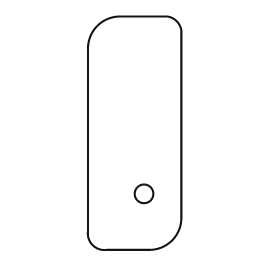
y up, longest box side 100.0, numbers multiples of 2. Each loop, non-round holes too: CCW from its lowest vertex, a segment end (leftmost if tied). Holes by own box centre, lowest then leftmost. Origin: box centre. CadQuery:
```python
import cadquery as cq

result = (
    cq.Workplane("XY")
    .moveTo(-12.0, -50.0)
    .lineTo(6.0, -50.0)
    .threePointArc((16.0, -46.0), (20.0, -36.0))
    .lineTo(20.0, 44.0)
    .threePointArc((18.0, 48.0), (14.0, 50.0))
    .lineTo(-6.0, 50.0)
    .threePointArc((-16.0, 46.0), (-20.0, 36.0))
    .lineTo(-20.0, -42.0)
    .threePointArc((-18.0, -48.0), (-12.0, -50.0))
    .close()
    .moveTo(4.0, -26.0)
    .circle(4.0)
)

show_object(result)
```